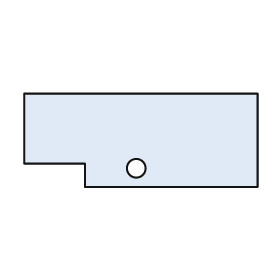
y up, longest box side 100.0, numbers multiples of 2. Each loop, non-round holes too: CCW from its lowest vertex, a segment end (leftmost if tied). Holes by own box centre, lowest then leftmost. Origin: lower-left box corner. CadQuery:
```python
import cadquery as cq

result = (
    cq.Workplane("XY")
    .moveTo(26.0, 0.0)
    .lineTo(100.0, 0.0)
    .lineTo(100.0, 40.0)
    .lineTo(0.0, 40.0)
    .lineTo(0.0, 10.0)
    .lineTo(26.0, 10.0)
    .close()
    .moveTo(48.0, 8.0)
    .circle(4.0)
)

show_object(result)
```